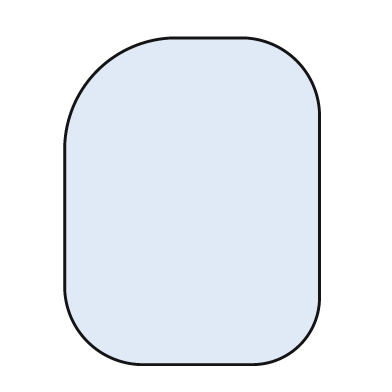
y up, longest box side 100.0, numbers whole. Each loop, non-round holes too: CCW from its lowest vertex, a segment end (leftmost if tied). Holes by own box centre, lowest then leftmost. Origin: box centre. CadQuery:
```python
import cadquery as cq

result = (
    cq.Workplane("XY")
    .moveTo(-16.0, -50.0)
    .lineTo(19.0, -50.0)
    .threePointArc((33.0, -44.0), (39.0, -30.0))
    .lineTo(39.0, 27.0)
    .threePointArc((32.0, 43.0), (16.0, 50.0))
    .lineTo(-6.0, 50.0)
    .threePointArc((-29.0, 40.0), (-39.0, 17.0))
    .lineTo(-39.0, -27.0)
    .threePointArc((-32.0, -43.0), (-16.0, -50.0))
    .close()
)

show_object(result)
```